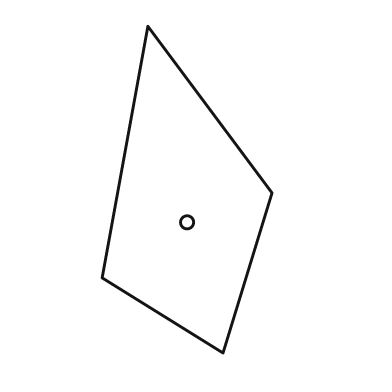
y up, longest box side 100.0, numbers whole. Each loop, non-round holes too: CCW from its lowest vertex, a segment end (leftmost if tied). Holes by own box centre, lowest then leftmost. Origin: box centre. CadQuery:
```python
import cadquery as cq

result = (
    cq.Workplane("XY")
    .moveTo(11.0, -50.0)
    .lineTo(26.0, -1.0)
    .lineTo(-12.0, 50.0)
    .lineTo(-26.0, -27.0)
    .close()
    .moveTo(0.0, -10.0)
    .circle(2.0)
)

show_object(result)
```